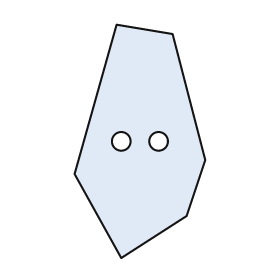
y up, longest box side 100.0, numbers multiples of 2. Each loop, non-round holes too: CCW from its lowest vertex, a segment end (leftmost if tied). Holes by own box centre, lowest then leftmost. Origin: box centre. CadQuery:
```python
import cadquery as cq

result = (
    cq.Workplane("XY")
    .moveTo(-8.0, -50.0)
    .lineTo(20.0, -32.0)
    .lineTo(28.0, -8.0)
    .lineTo(14.0, 46.0)
    .lineTo(-10.0, 50.0)
    .lineTo(-28.0, -14.0)
    .close()
    .moveTo(-8.0, 0.0)
    .circle(4.0)
    .moveTo(8.0, 0.0)
    .circle(4.0)
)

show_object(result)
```